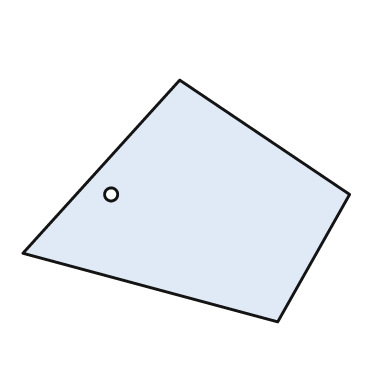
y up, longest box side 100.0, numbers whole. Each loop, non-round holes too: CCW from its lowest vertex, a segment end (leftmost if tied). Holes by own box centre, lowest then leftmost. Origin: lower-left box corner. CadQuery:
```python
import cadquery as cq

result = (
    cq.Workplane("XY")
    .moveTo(78.0, 0.0)
    .lineTo(100.0, 39.0)
    .lineTo(48.0, 74.0)
    .lineTo(0.0, 21.0)
    .close()
    .moveTo(27.0, 39.0)
    .circle(2.0)
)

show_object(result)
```